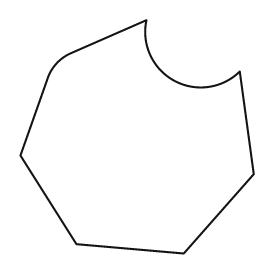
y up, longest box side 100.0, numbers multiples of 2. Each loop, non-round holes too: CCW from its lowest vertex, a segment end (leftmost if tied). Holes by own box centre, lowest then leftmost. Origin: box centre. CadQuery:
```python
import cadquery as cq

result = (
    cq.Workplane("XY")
    .moveTo(20.0, -50.0)
    .lineTo(50.0, -16.0)
    .lineTo(44.0, 28.0)
    .threePointArc((16.0, 24.0), (4.0, 50.0))
    .lineTo(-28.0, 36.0)
    .threePointArc((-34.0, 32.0), (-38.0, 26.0))
    .lineTo(-50.0, -8.0)
    .lineTo(-26.0, -46.0)
    .close()
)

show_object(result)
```